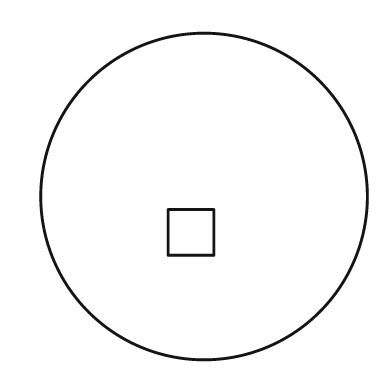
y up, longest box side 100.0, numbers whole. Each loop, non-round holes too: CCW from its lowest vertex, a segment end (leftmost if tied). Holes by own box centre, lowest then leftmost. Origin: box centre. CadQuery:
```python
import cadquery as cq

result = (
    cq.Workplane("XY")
    .moveTo(0.0, 0.0)
    .circle(50.0)
    .moveTo(-11.0, -18.0)
    .lineTo(3.0, -18.0)
    .lineTo(3.0, -4.0)
    .lineTo(-11.0, -4.0)
    .close()
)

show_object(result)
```